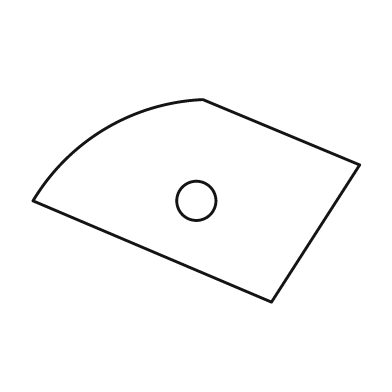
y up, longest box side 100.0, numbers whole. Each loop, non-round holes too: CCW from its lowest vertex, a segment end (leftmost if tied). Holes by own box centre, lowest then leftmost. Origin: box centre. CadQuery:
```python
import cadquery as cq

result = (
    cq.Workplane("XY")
    .moveTo(23.0, -31.0)
    .lineTo(50.0, 11.0)
    .lineTo(2.0, 31.0)
    .threePointArc((-28.0, 22.0), (-50.0, 0.0))
    .close()
    .moveTo(0.0, 0.0)
    .circle(6.0)
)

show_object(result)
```